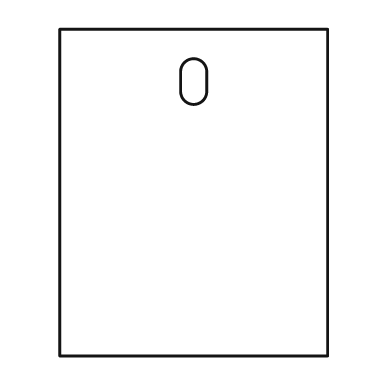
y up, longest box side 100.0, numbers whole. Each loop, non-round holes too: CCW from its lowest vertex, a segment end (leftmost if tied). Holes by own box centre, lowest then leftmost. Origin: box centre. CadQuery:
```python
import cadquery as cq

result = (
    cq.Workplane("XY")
    .moveTo(-41.0, -50.0)
    .lineTo(41.0, -50.0)
    .lineTo(41.0, 50.0)
    .lineTo(-41.0, 50.0)
    .close()
    .moveTo(-4.0, 31.0)
    .threePointArc((0.0, 27.0), (4.0, 31.0))
    .lineTo(4.0, 37.0)
    .threePointArc((0.0, 41.0), (-4.0, 37.0))
    .close()
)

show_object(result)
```